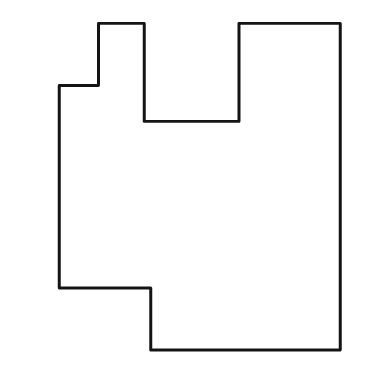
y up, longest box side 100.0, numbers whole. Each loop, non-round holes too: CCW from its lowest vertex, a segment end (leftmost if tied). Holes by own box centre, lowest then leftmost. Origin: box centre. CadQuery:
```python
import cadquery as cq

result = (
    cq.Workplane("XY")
    .moveTo(-15.0, -50.0)
    .lineTo(43.0, -50.0)
    .lineTo(43.0, 50.0)
    .lineTo(12.0, 50.0)
    .lineTo(12.0, 20.0)
    .lineTo(-17.0, 20.0)
    .lineTo(-17.0, 50.0)
    .lineTo(-31.0, 50.0)
    .lineTo(-31.0, 31.0)
    .lineTo(-43.0, 31.0)
    .lineTo(-43.0, -31.0)
    .lineTo(-15.0, -31.0)
    .close()
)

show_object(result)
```